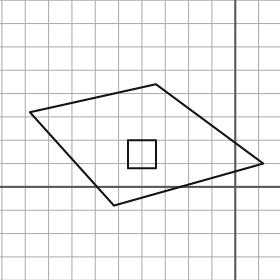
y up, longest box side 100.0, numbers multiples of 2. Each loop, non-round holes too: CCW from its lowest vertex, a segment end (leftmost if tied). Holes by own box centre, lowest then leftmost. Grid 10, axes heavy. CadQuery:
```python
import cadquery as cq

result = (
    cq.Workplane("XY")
    .moveTo(-52.0, -8.0)
    .lineTo(12.0, 10.0)
    .lineTo(-34.0, 44.0)
    .lineTo(-88.0, 32.0)
    .close()
    .moveTo(-46.0, 8.0)
    .lineTo(-34.0, 8.0)
    .lineTo(-34.0, 20.0)
    .lineTo(-46.0, 20.0)
    .close()
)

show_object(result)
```